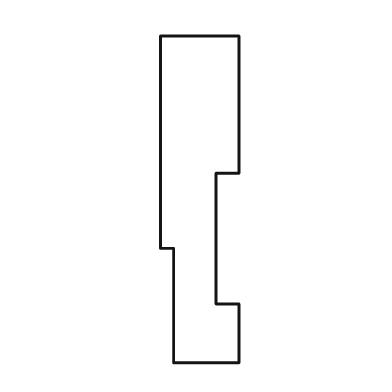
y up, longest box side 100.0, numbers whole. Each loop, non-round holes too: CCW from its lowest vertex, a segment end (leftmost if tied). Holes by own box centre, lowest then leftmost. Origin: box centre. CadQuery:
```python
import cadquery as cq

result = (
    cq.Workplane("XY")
    .moveTo(-8.0, -50.0)
    .lineTo(12.0, -50.0)
    .lineTo(12.0, -32.0)
    .lineTo(5.0, -32.0)
    .lineTo(5.0, 8.0)
    .lineTo(12.0, 8.0)
    .lineTo(12.0, 50.0)
    .lineTo(-12.0, 50.0)
    .lineTo(-12.0, -15.0)
    .lineTo(-8.0, -15.0)
    .close()
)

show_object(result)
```